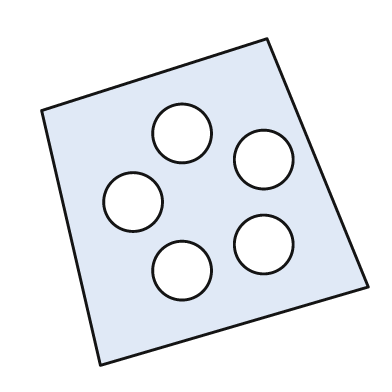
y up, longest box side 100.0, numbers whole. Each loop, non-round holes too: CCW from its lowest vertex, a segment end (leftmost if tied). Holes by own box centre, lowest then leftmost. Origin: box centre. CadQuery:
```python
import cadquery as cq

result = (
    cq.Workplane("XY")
    .moveTo(-32.0, -50.0)
    .lineTo(50.0, -26.0)
    .lineTo(19.0, 50.0)
    .lineTo(-50.0, 28.0)
    .close()
    .moveTo(-7.0, -21.0)
    .circle(9.0)
    .moveTo(18.0, -13.0)
    .circle(9.0)
    .moveTo(-22.0, 0.0)
    .circle(9.0)
    .moveTo(18.0, 13.0)
    .circle(9.0)
    .moveTo(-7.0, 21.0)
    .circle(9.0)
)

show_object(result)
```